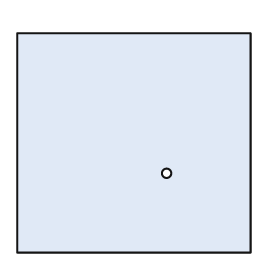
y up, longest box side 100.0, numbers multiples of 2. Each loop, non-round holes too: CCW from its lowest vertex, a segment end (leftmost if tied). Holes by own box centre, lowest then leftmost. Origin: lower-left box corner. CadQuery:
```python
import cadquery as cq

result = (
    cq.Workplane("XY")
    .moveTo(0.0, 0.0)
    .lineTo(100.0, 0.0)
    .lineTo(100.0, 94.0)
    .lineTo(0.0, 94.0)
    .close()
    .moveTo(64.0, 34.0)
    .circle(2.0)
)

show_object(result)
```